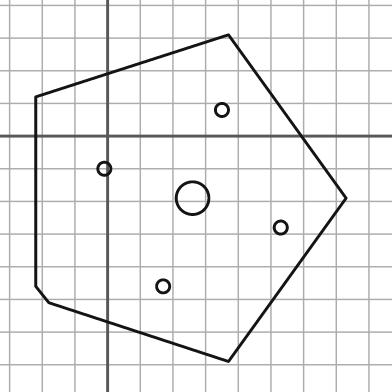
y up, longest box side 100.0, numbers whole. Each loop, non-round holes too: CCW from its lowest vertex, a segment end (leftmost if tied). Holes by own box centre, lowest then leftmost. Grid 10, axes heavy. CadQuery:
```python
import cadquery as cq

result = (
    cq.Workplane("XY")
    .moveTo(37.0, -69.0)
    .lineTo(73.0, -19.0)
    .lineTo(37.0, 31.0)
    .lineTo(-22.0, 12.0)
    .lineTo(-22.0, -46.0)
    .lineTo(-18.0, -51.0)
    .close()
    .moveTo(17.0, -46.0)
    .circle(2.0)
    .moveTo(53.0, -28.0)
    .circle(2.0)
    .moveTo(26.0, -19.0)
    .circle(5.0)
    .moveTo(-1.0, -10.0)
    .circle(2.0)
    .moveTo(35.0, 8.0)
    .circle(2.0)
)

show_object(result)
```